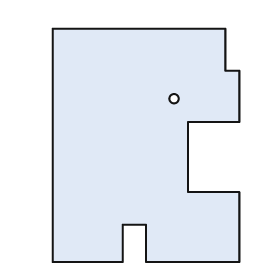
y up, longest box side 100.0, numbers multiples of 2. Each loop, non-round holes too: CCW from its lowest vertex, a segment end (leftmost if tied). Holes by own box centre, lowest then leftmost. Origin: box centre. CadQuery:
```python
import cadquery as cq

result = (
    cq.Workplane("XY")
    .moveTo(-40.0, -50.0)
    .lineTo(-10.0, -50.0)
    .lineTo(-10.0, -34.0)
    .lineTo(0.0, -34.0)
    .lineTo(0.0, -50.0)
    .lineTo(40.0, -50.0)
    .lineTo(40.0, -20.0)
    .lineTo(18.0, -20.0)
    .lineTo(18.0, 10.0)
    .lineTo(40.0, 10.0)
    .lineTo(40.0, 32.0)
    .lineTo(34.0, 32.0)
    .lineTo(34.0, 50.0)
    .lineTo(-40.0, 50.0)
    .close()
    .moveTo(12.0, 20.0)
    .circle(2.0)
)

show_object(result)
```